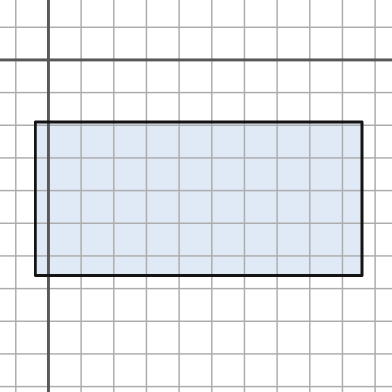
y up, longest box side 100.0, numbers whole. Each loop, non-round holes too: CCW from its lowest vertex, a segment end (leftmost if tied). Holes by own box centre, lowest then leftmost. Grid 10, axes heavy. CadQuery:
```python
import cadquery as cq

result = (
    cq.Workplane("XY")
    .moveTo(-4.0, -66.0)
    .lineTo(96.0, -66.0)
    .lineTo(96.0, -19.0)
    .lineTo(-4.0, -19.0)
    .close()
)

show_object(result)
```